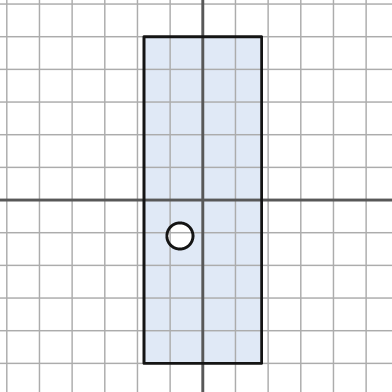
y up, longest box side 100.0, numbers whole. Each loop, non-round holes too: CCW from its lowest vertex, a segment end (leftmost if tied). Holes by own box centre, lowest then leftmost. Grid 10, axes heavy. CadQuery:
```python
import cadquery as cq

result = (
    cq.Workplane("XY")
    .moveTo(-18.0, -50.0)
    .lineTo(18.0, -50.0)
    .lineTo(18.0, 50.0)
    .lineTo(-18.0, 50.0)
    .close()
    .moveTo(-7.0, -11.0)
    .circle(4.0)
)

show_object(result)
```